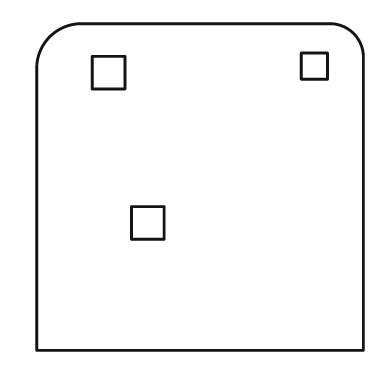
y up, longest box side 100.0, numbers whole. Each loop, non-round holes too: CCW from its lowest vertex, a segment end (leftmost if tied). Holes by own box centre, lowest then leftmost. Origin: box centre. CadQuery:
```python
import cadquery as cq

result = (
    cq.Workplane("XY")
    .moveTo(-50.0, -50.0)
    .lineTo(50.0, -50.0)
    .lineTo(50.0, 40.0)
    .threePointArc((47.0, 47.0), (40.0, 50.0))
    .lineTo(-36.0, 50.0)
    .threePointArc((-46.0, 46.0), (-50.0, 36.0))
    .close()
    .moveTo(-21.0, -16.0)
    .lineTo(-11.0, -16.0)
    .lineTo(-11.0, -6.0)
    .lineTo(-21.0, -6.0)
    .close()
    .moveTo(-33.0, 30.0)
    .lineTo(-23.0, 30.0)
    .lineTo(-23.0, 40.0)
    .lineTo(-33.0, 40.0)
    .close()
    .moveTo(31.0, 33.0)
    .lineTo(39.0, 33.0)
    .lineTo(39.0, 41.0)
    .lineTo(31.0, 41.0)
    .close()
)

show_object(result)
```